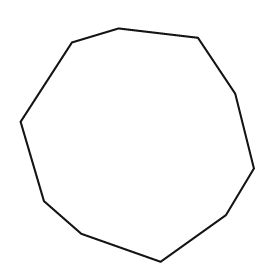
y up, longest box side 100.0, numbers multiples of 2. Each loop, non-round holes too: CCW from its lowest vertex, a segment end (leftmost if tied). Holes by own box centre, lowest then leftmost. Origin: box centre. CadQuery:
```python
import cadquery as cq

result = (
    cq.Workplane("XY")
    .moveTo(10.0, -50.0)
    .lineTo(38.0, -30.0)
    .lineTo(50.0, -10.0)
    .lineTo(42.0, 22.0)
    .lineTo(26.0, 46.0)
    .lineTo(-8.0, 50.0)
    .lineTo(-28.0, 44.0)
    .lineTo(-50.0, 10.0)
    .lineTo(-40.0, -24.0)
    .lineTo(-24.0, -38.0)
    .close()
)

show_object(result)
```